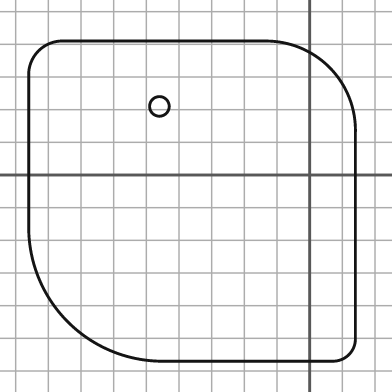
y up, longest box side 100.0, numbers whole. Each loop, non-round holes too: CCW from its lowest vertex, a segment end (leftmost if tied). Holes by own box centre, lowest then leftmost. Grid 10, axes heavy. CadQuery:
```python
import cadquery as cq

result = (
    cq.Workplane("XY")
    .moveTo(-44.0, -57.0)
    .lineTo(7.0, -57.0)
    .threePointArc((12.0, -55.0), (14.0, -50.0))
    .lineTo(14.0, 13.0)
    .threePointArc((6.0, 33.0), (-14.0, 41.0))
    .lineTo(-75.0, 41.0)
    .threePointArc((-83.0, 38.0), (-86.0, 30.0))
    .lineTo(-86.0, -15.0)
    .threePointArc((-74.0, -45.0), (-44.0, -57.0))
    .close()
    .moveTo(-46.0, 21.0)
    .circle(3.0)
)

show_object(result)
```